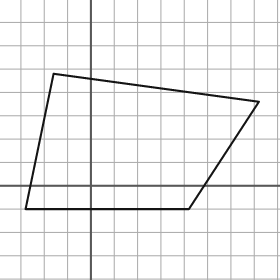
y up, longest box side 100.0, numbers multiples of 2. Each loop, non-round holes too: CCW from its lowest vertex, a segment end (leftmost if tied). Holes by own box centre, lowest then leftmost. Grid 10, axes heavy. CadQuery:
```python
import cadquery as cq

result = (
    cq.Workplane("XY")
    .moveTo(-28.0, -10.0)
    .lineTo(42.0, -10.0)
    .lineTo(72.0, 36.0)
    .lineTo(-16.0, 48.0)
    .close()
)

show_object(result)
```